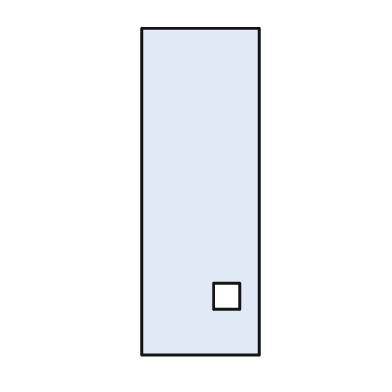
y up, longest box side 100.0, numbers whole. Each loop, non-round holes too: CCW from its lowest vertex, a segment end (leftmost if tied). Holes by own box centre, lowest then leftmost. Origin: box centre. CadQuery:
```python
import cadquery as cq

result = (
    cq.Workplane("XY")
    .moveTo(-18.0, -50.0)
    .lineTo(18.0, -50.0)
    .lineTo(18.0, 50.0)
    .lineTo(-18.0, 50.0)
    .close()
    .moveTo(4.0, -36.0)
    .lineTo(12.0, -36.0)
    .lineTo(12.0, -28.0)
    .lineTo(4.0, -28.0)
    .close()
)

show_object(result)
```